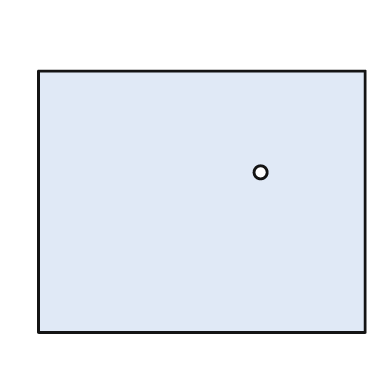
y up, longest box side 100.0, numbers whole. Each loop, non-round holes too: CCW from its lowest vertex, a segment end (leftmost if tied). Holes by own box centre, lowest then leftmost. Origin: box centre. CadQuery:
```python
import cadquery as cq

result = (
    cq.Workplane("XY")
    .moveTo(-50.0, -40.0)
    .lineTo(50.0, -40.0)
    .lineTo(50.0, 40.0)
    .lineTo(-50.0, 40.0)
    .close()
    .moveTo(18.0, 9.0)
    .circle(2.0)
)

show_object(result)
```